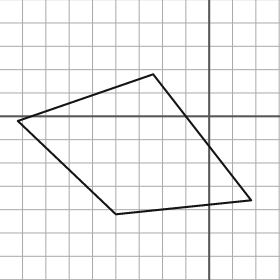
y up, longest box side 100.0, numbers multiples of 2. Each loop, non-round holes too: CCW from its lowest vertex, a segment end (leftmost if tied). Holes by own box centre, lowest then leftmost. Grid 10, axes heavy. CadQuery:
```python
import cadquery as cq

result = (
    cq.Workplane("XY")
    .moveTo(-40.0, -42.0)
    .lineTo(18.0, -36.0)
    .lineTo(-24.0, 18.0)
    .lineTo(-82.0, -2.0)
    .close()
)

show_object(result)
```